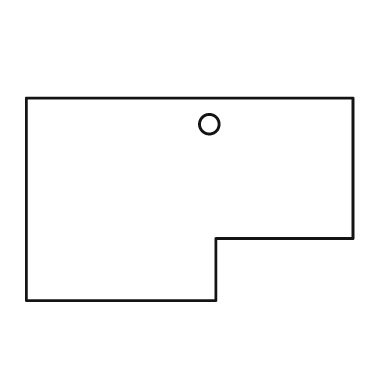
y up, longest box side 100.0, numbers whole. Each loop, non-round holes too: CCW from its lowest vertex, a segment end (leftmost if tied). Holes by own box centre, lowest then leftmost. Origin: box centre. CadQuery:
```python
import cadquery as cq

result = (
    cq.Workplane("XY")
    .moveTo(-50.0, -31.0)
    .lineTo(8.0, -31.0)
    .lineTo(8.0, -12.0)
    .lineTo(50.0, -12.0)
    .lineTo(50.0, 31.0)
    .lineTo(-50.0, 31.0)
    .close()
    .moveTo(6.0, 23.0)
    .circle(3.0)
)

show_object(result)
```